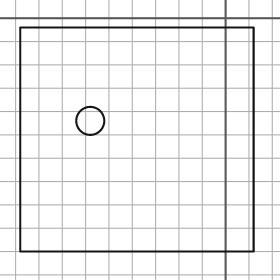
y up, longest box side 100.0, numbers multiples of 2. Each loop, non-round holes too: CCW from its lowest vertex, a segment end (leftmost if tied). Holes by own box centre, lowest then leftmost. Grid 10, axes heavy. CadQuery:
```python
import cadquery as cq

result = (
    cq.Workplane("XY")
    .moveTo(-88.0, -100.0)
    .lineTo(12.0, -100.0)
    .lineTo(12.0, -4.0)
    .lineTo(-88.0, -4.0)
    .close()
    .moveTo(-58.0, -44.0)
    .circle(6.0)
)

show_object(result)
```